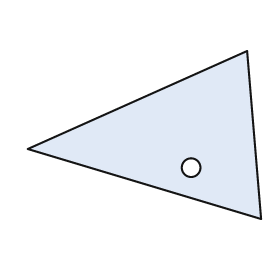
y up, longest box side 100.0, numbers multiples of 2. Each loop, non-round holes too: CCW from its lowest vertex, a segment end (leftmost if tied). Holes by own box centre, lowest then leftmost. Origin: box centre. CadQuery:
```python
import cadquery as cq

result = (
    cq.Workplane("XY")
    .moveTo(50.0, -36.0)
    .lineTo(44.0, 36.0)
    .lineTo(-50.0, -6.0)
    .close()
    .moveTo(20.0, -14.0)
    .circle(4.0)
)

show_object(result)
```